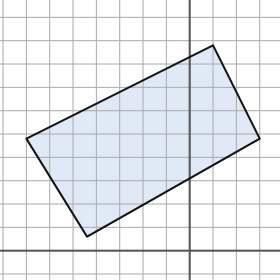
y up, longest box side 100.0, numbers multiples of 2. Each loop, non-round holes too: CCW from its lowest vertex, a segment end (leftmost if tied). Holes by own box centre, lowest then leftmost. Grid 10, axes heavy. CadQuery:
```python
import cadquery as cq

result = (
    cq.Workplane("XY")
    .moveTo(-44.0, 6.0)
    .lineTo(30.0, 48.0)
    .lineTo(10.0, 88.0)
    .lineTo(-70.0, 48.0)
    .close()
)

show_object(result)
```